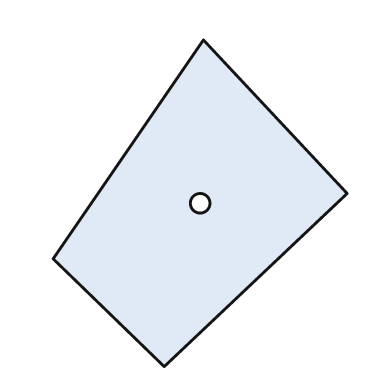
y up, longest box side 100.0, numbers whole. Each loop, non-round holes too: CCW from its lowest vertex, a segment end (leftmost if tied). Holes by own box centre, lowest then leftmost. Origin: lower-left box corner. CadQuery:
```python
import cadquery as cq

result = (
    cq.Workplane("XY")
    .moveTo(34.0, 0.0)
    .lineTo(90.0, 53.0)
    .lineTo(46.0, 100.0)
    .lineTo(0.0, 33.0)
    .close()
    .moveTo(45.0, 50.0)
    .circle(3.0)
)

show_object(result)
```